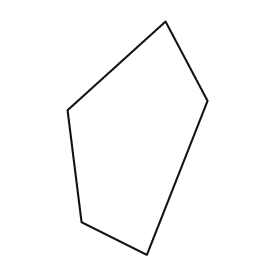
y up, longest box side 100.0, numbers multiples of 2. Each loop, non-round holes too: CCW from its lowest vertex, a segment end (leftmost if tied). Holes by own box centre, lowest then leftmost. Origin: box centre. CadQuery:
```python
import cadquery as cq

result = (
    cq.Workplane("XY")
    .moveTo(4.0, -50.0)
    .lineTo(30.0, 16.0)
    .lineTo(12.0, 50.0)
    .lineTo(-30.0, 12.0)
    .lineTo(-24.0, -36.0)
    .close()
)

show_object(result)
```